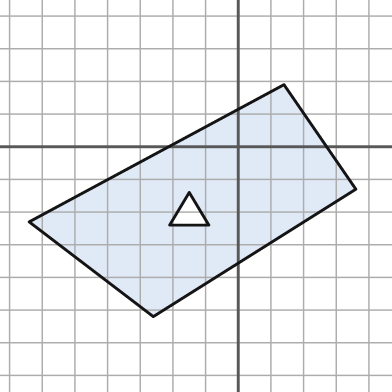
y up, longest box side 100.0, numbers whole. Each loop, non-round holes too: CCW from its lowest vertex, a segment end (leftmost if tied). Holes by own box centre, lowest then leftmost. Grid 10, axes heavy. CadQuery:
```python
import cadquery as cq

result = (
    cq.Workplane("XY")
    .moveTo(-26.0, -52.0)
    .lineTo(36.0, -13.0)
    .lineTo(14.0, 19.0)
    .lineTo(-64.0, -23.0)
    .close()
    .moveTo(-21.0, -24.0)
    .lineTo(-9.0, -24.0)
    .lineTo(-15.0, -14.0)
    .close()
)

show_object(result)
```